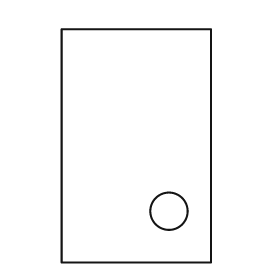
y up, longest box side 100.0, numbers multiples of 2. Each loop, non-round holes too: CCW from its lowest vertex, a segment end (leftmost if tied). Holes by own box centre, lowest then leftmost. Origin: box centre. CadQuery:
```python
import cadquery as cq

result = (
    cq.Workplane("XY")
    .moveTo(-32.0, -50.0)
    .lineTo(32.0, -50.0)
    .lineTo(32.0, 50.0)
    .lineTo(-32.0, 50.0)
    .close()
    .moveTo(14.0, -28.0)
    .circle(8.0)
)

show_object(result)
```